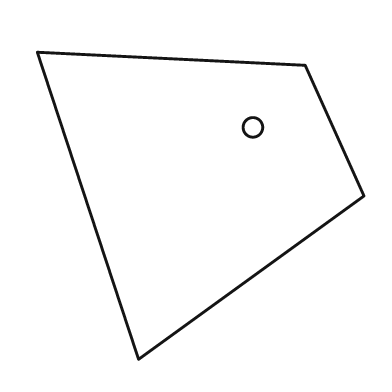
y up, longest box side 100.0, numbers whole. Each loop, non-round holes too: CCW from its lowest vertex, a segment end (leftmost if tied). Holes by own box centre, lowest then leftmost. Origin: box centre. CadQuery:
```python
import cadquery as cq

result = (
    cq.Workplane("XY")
    .moveTo(-19.0, -47.0)
    .lineTo(50.0, 3.0)
    .lineTo(32.0, 43.0)
    .lineTo(-50.0, 47.0)
    .close()
    .moveTo(16.0, 24.0)
    .circle(3.0)
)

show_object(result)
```